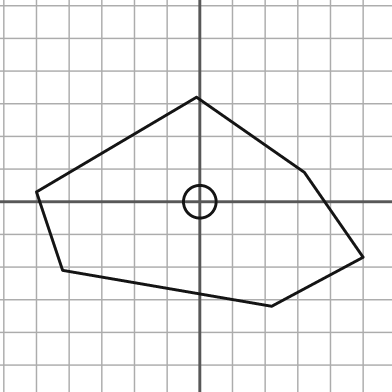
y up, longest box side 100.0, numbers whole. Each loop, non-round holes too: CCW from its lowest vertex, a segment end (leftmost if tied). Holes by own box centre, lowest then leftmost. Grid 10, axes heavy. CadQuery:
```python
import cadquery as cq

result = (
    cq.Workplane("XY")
    .moveTo(22.0, -32.0)
    .lineTo(50.0, -17.0)
    .lineTo(32.0, 9.0)
    .lineTo(-1.0, 32.0)
    .lineTo(-50.0, 3.0)
    .lineTo(-42.0, -21.0)
    .close()
    .moveTo(0.0, 0.0)
    .circle(5.0)
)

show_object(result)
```